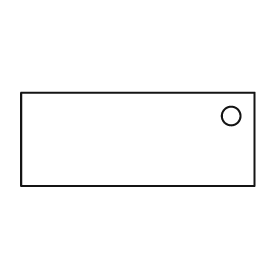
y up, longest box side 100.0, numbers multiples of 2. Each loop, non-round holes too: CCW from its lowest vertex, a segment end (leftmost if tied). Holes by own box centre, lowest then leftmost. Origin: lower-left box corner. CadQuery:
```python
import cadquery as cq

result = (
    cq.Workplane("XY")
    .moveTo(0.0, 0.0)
    .lineTo(100.0, 0.0)
    .lineTo(100.0, 40.0)
    .lineTo(0.0, 40.0)
    .close()
    .moveTo(90.0, 30.0)
    .circle(4.0)
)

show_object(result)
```